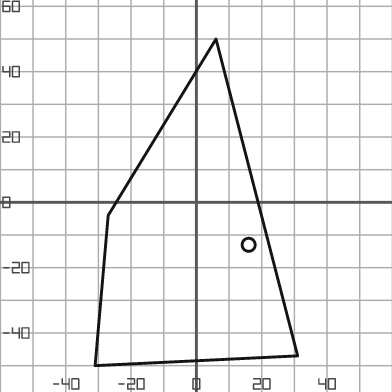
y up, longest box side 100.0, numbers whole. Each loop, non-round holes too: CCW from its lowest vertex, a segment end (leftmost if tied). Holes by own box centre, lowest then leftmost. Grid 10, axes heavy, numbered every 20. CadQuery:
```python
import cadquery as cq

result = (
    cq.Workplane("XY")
    .moveTo(-31.0, -50.0)
    .lineTo(31.0, -47.0)
    .lineTo(6.0, 50.0)
    .lineTo(-27.0, -4.0)
    .close()
    .moveTo(16.0, -13.0)
    .circle(2.0)
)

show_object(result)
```